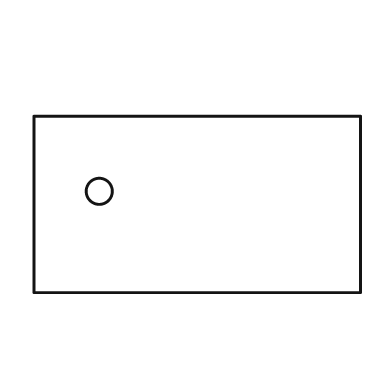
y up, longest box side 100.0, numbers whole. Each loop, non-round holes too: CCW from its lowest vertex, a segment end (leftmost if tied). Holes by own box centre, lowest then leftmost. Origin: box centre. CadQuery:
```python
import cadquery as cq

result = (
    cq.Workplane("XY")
    .moveTo(-50.0, -27.0)
    .lineTo(50.0, -27.0)
    .lineTo(50.0, 27.0)
    .lineTo(-50.0, 27.0)
    .close()
    .moveTo(-30.0, 4.0)
    .circle(4.0)
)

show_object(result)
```